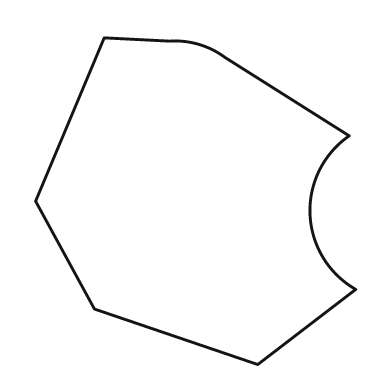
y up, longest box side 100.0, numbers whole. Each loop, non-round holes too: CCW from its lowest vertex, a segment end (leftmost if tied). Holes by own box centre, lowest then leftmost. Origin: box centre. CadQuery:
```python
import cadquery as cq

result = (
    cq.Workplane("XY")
    .moveTo(19.0, -50.0)
    .lineTo(49.0, -27.0)
    .threePointArc((35.0, -4.0), (47.0, 20.0))
    .lineTo(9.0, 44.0)
    .threePointArc((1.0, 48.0), (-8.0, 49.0))
    .lineTo(-28.0, 50.0)
    .lineTo(-49.0, 0.0)
    .lineTo(-31.0, -33.0)
    .close()
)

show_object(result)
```